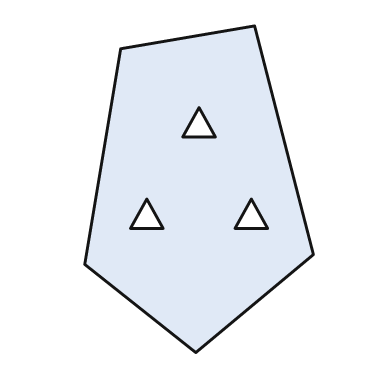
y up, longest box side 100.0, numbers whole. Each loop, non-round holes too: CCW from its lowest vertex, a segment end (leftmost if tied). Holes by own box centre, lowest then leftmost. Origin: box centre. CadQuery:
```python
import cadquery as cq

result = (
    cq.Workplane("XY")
    .moveTo(-1.0, -50.0)
    .lineTo(35.0, -20.0)
    .lineTo(17.0, 50.0)
    .lineTo(-24.0, 43.0)
    .lineTo(-35.0, -23.0)
    .close()
    .moveTo(-21.0, -12.0)
    .lineTo(-11.0, -12.0)
    .lineTo(-16.0, -3.0)
    .close()
    .moveTo(11.0, -12.0)
    .lineTo(21.0, -12.0)
    .lineTo(16.0, -3.0)
    .close()
    .moveTo(-5.0, 16.0)
    .lineTo(5.0, 16.0)
    .lineTo(0.0, 25.0)
    .close()
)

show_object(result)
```